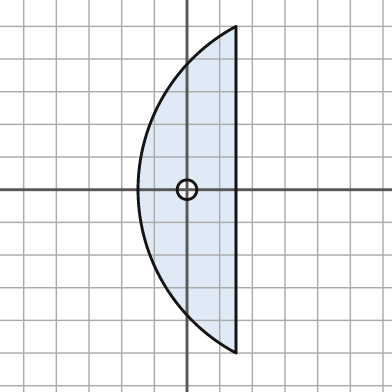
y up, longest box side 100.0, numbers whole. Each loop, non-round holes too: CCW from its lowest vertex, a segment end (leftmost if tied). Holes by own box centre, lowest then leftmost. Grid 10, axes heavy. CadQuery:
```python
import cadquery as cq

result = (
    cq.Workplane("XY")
    .moveTo(15.0, -50.0)
    .lineTo(15.0, 50.0)
    .threePointArc((-15.0, 0.0), (15.0, -50.0))
    .close()
    .moveTo(0.0, 0.0)
    .circle(3.0)
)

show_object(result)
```